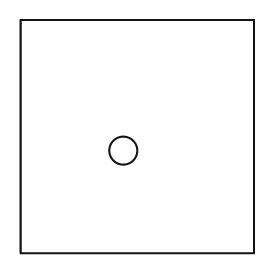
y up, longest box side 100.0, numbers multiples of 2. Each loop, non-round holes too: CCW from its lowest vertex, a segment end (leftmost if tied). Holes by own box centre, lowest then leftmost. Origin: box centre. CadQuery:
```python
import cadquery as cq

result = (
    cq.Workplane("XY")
    .moveTo(-50.0, -50.0)
    .lineTo(50.0, -50.0)
    .lineTo(50.0, 50.0)
    .lineTo(-50.0, 50.0)
    .close()
    .moveTo(-6.0, -6.0)
    .circle(6.0)
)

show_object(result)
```